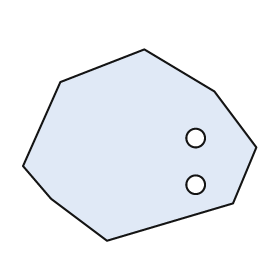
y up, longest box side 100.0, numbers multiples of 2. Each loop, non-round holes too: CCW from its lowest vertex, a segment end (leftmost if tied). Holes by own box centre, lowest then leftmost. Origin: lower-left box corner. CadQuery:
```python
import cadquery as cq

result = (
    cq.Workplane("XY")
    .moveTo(36.0, 0.0)
    .lineTo(90.0, 16.0)
    .lineTo(100.0, 40.0)
    .lineTo(82.0, 64.0)
    .lineTo(52.0, 82.0)
    .lineTo(16.0, 68.0)
    .lineTo(0.0, 32.0)
    .lineTo(12.0, 18.0)
    .close()
    .moveTo(74.0, 24.0)
    .circle(4.0)
    .moveTo(74.0, 44.0)
    .circle(4.0)
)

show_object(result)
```